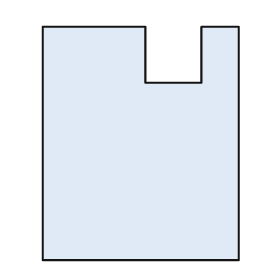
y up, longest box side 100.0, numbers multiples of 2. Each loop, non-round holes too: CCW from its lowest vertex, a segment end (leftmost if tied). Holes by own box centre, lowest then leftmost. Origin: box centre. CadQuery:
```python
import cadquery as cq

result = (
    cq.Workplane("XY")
    .moveTo(-42.0, -50.0)
    .lineTo(42.0, -50.0)
    .lineTo(42.0, 50.0)
    .lineTo(26.0, 50.0)
    .lineTo(26.0, 26.0)
    .lineTo(2.0, 26.0)
    .lineTo(2.0, 50.0)
    .lineTo(-42.0, 50.0)
    .close()
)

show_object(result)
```